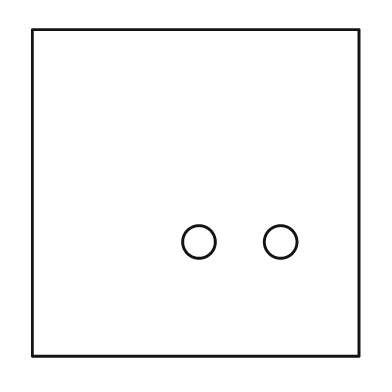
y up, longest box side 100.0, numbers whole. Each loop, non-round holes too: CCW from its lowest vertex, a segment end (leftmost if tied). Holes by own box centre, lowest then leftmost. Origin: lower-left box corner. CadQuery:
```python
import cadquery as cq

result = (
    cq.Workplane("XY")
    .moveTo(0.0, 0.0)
    .lineTo(100.0, 0.0)
    .lineTo(100.0, 100.0)
    .lineTo(0.0, 100.0)
    .close()
    .moveTo(51.0, 35.0)
    .circle(5.0)
    .moveTo(76.0, 35.0)
    .circle(5.0)
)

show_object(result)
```